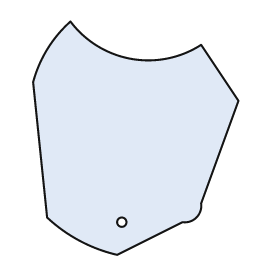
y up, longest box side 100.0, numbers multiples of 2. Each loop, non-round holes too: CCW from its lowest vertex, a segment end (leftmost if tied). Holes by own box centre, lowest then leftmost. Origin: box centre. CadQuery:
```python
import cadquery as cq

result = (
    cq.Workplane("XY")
    .moveTo(-8.0, -50.0)
    .lineTo(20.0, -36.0)
    .threePointArc((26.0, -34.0), (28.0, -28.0))
    .lineTo(44.0, 16.0)
    .lineTo(28.0, 40.0)
    .threePointArc((-2.0, 34.0), (-28.0, 50.0))
    .threePointArc((-38.0, 38.0), (-44.0, 24.0))
    .lineTo(-38.0, -34.0)
    .threePointArc((-24.0, -44.0), (-8.0, -50.0))
    .close()
    .moveTo(-6.0, -36.0)
    .circle(2.0)
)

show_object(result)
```